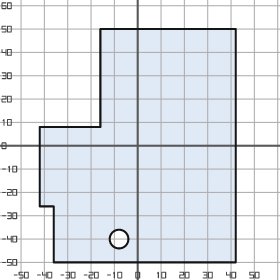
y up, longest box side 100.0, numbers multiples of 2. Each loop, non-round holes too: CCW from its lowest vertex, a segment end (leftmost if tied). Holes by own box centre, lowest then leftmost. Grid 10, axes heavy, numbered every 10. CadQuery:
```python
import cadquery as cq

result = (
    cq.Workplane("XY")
    .moveTo(-36.0, -50.0)
    .lineTo(42.0, -50.0)
    .lineTo(42.0, 50.0)
    .lineTo(-16.0, 50.0)
    .lineTo(-16.0, 8.0)
    .lineTo(-42.0, 8.0)
    .lineTo(-42.0, -26.0)
    .lineTo(-36.0, -26.0)
    .close()
    .moveTo(-8.0, -40.0)
    .circle(4.0)
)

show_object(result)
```